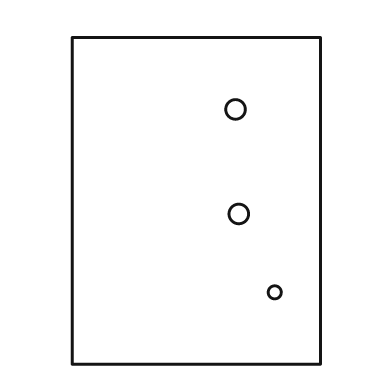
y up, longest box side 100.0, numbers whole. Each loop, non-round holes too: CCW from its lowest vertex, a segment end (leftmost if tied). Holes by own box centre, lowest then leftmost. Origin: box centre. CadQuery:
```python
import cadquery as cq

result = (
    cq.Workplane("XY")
    .moveTo(-38.0, -50.0)
    .lineTo(38.0, -50.0)
    .lineTo(38.0, 50.0)
    .lineTo(-38.0, 50.0)
    .close()
    .moveTo(24.0, -28.0)
    .circle(2.0)
    .moveTo(13.0, -4.0)
    .circle(3.0)
    .moveTo(12.0, 28.0)
    .circle(3.0)
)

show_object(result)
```